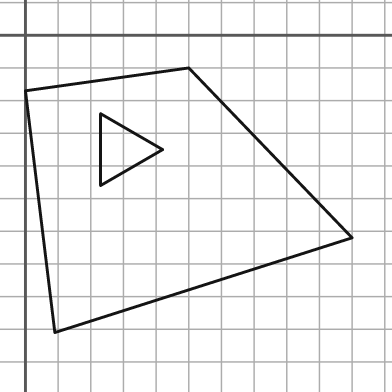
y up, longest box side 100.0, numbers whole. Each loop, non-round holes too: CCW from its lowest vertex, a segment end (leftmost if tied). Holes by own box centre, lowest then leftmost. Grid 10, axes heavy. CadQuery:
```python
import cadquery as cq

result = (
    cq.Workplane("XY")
    .moveTo(9.0, -91.0)
    .lineTo(100.0, -62.0)
    .lineTo(50.0, -10.0)
    .lineTo(0.0, -17.0)
    .close()
    .moveTo(23.0, -46.0)
    .lineTo(42.0, -35.0)
    .lineTo(23.0, -24.0)
    .close()
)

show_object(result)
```